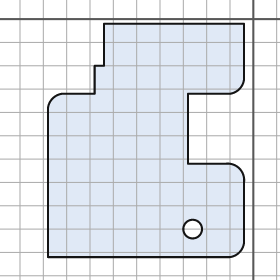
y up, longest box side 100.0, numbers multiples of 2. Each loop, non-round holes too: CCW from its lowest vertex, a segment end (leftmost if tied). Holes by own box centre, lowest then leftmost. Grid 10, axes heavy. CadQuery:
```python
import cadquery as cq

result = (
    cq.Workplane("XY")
    .moveTo(-88.0, -102.0)
    .lineTo(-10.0, -102.0)
    .threePointArc((-6.0, -100.0), (-4.0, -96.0))
    .lineTo(-4.0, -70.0)
    .threePointArc((-6.0, -64.0), (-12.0, -62.0))
    .lineTo(-28.0, -62.0)
    .lineTo(-28.0, -32.0)
    .lineTo(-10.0, -32.0)
    .threePointArc((-6.0, -30.0), (-4.0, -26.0))
    .lineTo(-4.0, -2.0)
    .lineTo(-64.0, -2.0)
    .lineTo(-64.0, -20.0)
    .lineTo(-68.0, -20.0)
    .lineTo(-68.0, -32.0)
    .lineTo(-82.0, -32.0)
    .threePointArc((-86.0, -34.0), (-88.0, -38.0))
    .close()
    .moveTo(-26.0, -90.0)
    .circle(4.0)
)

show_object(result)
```